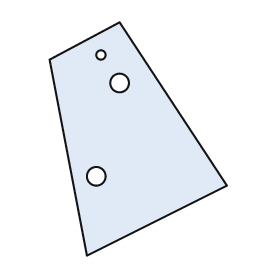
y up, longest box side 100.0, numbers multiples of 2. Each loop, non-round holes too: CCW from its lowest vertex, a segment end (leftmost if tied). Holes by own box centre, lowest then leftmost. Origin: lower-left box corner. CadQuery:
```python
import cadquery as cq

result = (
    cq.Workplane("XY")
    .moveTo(16.0, 0.0)
    .lineTo(76.0, 30.0)
    .lineTo(30.0, 100.0)
    .lineTo(0.0, 84.0)
    .close()
    .moveTo(20.0, 34.0)
    .circle(4.0)
    .moveTo(30.0, 74.0)
    .circle(4.0)
    .moveTo(22.0, 86.0)
    .circle(2.0)
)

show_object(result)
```